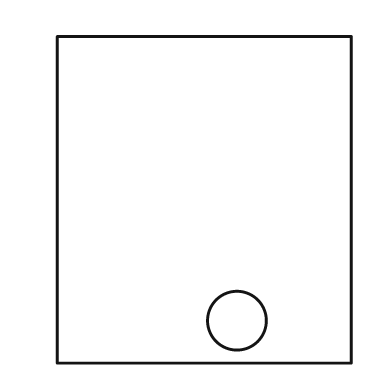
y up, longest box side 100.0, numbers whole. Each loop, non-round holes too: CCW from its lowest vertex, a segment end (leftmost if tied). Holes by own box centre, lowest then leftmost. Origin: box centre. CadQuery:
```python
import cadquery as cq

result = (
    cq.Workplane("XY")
    .moveTo(-45.0, -50.0)
    .lineTo(45.0, -50.0)
    .lineTo(45.0, 50.0)
    .lineTo(-45.0, 50.0)
    .close()
    .moveTo(10.0, -37.0)
    .circle(9.0)
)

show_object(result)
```